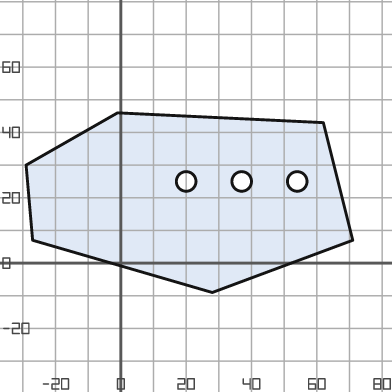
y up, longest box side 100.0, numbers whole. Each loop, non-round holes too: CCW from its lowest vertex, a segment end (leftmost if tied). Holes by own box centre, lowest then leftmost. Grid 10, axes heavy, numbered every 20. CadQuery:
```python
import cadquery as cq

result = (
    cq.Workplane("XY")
    .moveTo(28.0, -9.0)
    .lineTo(71.0, 7.0)
    .lineTo(62.0, 43.0)
    .lineTo(-1.0, 46.0)
    .lineTo(-29.0, 30.0)
    .lineTo(-27.0, 7.0)
    .close()
    .moveTo(20.0, 25.0)
    .circle(3.0)
    .moveTo(37.0, 25.0)
    .circle(3.0)
    .moveTo(54.0, 25.0)
    .circle(3.0)
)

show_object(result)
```